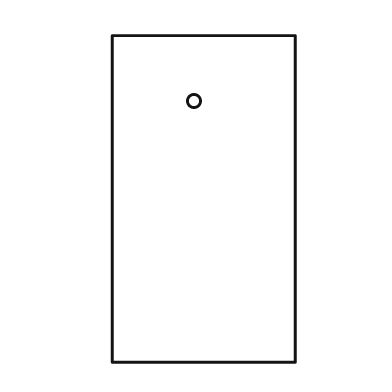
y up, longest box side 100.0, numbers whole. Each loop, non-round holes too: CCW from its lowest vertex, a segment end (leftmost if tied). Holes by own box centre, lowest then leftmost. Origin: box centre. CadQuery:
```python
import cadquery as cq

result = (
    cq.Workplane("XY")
    .moveTo(-28.0, -50.0)
    .lineTo(28.0, -50.0)
    .lineTo(28.0, 50.0)
    .lineTo(-28.0, 50.0)
    .close()
    .moveTo(-3.0, 30.0)
    .circle(2.0)
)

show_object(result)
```